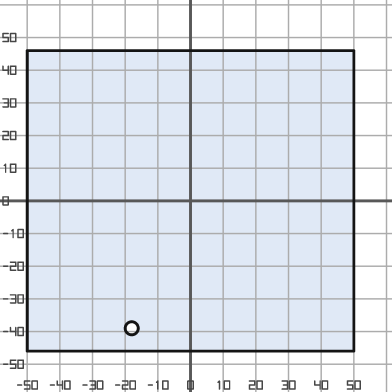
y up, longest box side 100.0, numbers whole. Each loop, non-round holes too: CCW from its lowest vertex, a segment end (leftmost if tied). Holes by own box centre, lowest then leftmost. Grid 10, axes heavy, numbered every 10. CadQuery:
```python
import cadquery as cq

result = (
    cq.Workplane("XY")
    .moveTo(-50.0, -46.0)
    .lineTo(50.0, -46.0)
    .lineTo(50.0, 46.0)
    .lineTo(-50.0, 46.0)
    .close()
    .moveTo(-18.0, -39.0)
    .circle(2.0)
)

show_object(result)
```